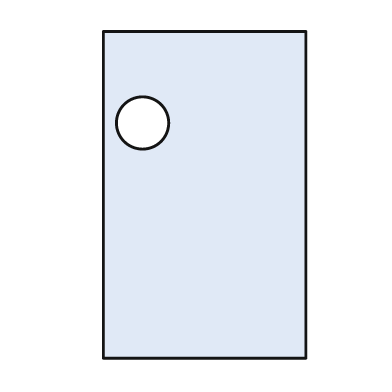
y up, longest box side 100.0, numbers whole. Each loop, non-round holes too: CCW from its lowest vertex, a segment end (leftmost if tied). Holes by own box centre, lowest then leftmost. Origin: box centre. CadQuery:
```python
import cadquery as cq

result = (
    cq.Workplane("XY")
    .moveTo(-31.0, -50.0)
    .lineTo(31.0, -50.0)
    .lineTo(31.0, 50.0)
    .lineTo(-31.0, 50.0)
    .close()
    .moveTo(-19.0, 22.0)
    .circle(8.0)
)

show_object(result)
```